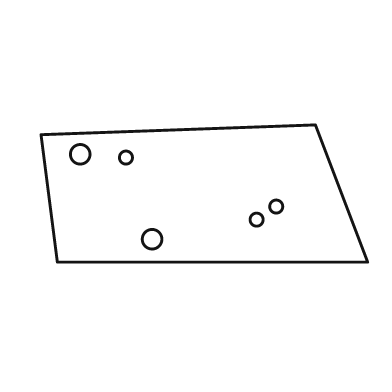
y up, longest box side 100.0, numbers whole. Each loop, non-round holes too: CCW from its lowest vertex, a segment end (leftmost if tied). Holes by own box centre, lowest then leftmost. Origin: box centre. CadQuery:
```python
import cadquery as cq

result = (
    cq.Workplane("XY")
    .moveTo(-45.0, -21.0)
    .lineTo(50.0, -21.0)
    .lineTo(34.0, 21.0)
    .lineTo(-50.0, 18.0)
    .close()
    .moveTo(-16.0, -14.0)
    .circle(3.0)
    .moveTo(16.0, -8.0)
    .circle(2.0)
    .moveTo(22.0, -4.0)
    .circle(2.0)
    .moveTo(-24.0, 11.0)
    .circle(2.0)
    .moveTo(-38.0, 12.0)
    .circle(3.0)
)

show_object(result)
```